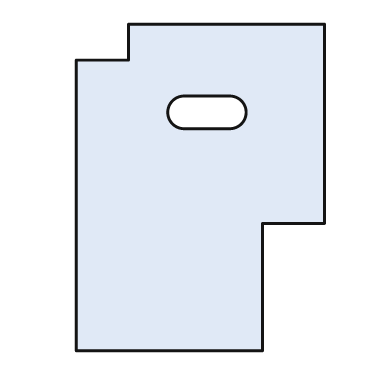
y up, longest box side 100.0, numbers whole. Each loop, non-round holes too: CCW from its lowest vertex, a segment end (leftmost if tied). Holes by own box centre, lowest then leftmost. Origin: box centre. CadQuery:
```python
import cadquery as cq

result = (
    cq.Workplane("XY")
    .moveTo(-38.0, -50.0)
    .lineTo(19.0, -50.0)
    .lineTo(19.0, -11.0)
    .lineTo(38.0, -11.0)
    .lineTo(38.0, 50.0)
    .lineTo(-22.0, 50.0)
    .lineTo(-22.0, 39.0)
    .lineTo(-38.0, 39.0)
    .close()
    .moveTo(-5.0, 18.0)
    .lineTo(9.0, 18.0)
    .threePointArc((14.0, 23.0), (9.0, 28.0))
    .lineTo(-5.0, 28.0)
    .threePointArc((-10.0, 23.0), (-5.0, 18.0))
    .close()
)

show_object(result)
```